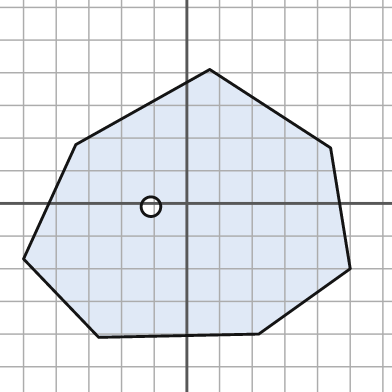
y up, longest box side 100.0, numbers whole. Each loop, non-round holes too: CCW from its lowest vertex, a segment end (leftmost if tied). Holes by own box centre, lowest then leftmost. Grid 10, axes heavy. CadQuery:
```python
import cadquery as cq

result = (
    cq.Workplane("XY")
    .moveTo(-27.0, -41.0)
    .lineTo(22.0, -40.0)
    .lineTo(50.0, -20.0)
    .lineTo(44.0, 17.0)
    .lineTo(7.0, 41.0)
    .lineTo(-34.0, 18.0)
    .lineTo(-50.0, -17.0)
    .close()
    .moveTo(-11.0, -1.0)
    .circle(3.0)
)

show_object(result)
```